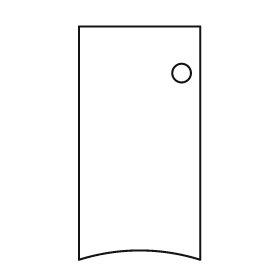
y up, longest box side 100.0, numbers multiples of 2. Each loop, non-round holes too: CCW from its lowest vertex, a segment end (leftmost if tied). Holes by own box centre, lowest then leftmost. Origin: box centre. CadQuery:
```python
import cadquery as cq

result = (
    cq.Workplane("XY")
    .moveTo(-26.0, -50.0)
    .threePointArc((0.0, -46.0), (26.0, -50.0))
    .lineTo(26.0, 50.0)
    .lineTo(-26.0, 50.0)
    .close()
    .moveTo(18.0, 30.0)
    .circle(4.0)
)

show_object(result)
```